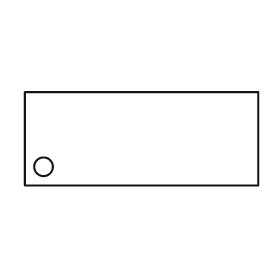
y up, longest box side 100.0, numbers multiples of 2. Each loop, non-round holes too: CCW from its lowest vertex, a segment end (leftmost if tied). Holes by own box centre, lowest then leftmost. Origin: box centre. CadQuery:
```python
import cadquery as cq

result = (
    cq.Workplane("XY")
    .moveTo(-50.0, -20.0)
    .lineTo(50.0, -20.0)
    .lineTo(50.0, 20.0)
    .lineTo(-50.0, 20.0)
    .close()
    .moveTo(-42.0, -12.0)
    .circle(4.0)
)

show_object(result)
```